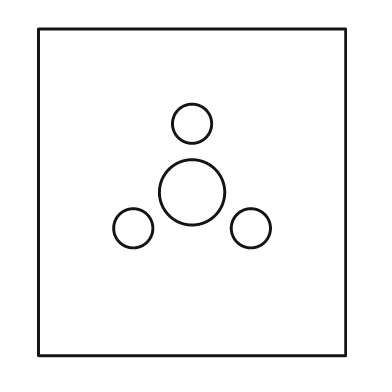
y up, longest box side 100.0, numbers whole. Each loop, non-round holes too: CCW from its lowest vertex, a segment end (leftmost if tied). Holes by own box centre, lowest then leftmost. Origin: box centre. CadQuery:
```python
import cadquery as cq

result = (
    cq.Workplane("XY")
    .moveTo(-47.0, -50.0)
    .lineTo(47.0, -50.0)
    .lineTo(47.0, 50.0)
    .lineTo(-47.0, 50.0)
    .close()
    .moveTo(-18.0, -11.0)
    .circle(6.0)
    .moveTo(18.0, -11.0)
    .circle(6.0)
    .moveTo(0.0, 0.0)
    .circle(10.0)
    .moveTo(0.0, 21.0)
    .circle(6.0)
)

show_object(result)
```